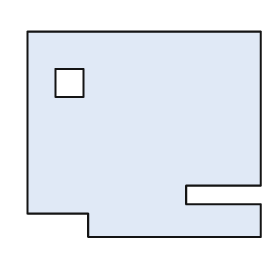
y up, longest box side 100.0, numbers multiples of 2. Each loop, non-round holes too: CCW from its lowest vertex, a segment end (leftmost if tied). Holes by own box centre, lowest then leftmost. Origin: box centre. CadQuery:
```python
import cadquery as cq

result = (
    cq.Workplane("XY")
    .moveTo(-24.0, -44.0)
    .lineTo(50.0, -44.0)
    .lineTo(50.0, -30.0)
    .lineTo(18.0, -30.0)
    .lineTo(18.0, -22.0)
    .lineTo(50.0, -22.0)
    .lineTo(50.0, 44.0)
    .lineTo(-50.0, 44.0)
    .lineTo(-50.0, -34.0)
    .lineTo(-24.0, -34.0)
    .close()
    .moveTo(-38.0, 16.0)
    .lineTo(-26.0, 16.0)
    .lineTo(-26.0, 28.0)
    .lineTo(-38.0, 28.0)
    .close()
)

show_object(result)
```